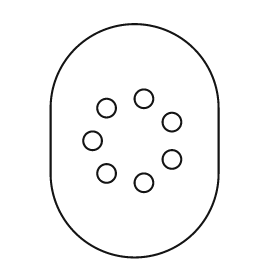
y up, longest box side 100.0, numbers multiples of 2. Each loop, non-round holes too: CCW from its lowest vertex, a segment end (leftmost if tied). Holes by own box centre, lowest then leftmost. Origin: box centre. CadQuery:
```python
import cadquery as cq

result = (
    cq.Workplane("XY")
    .moveTo(-36.0, -14.0)
    .threePointArc((0.0, -50.0), (36.0, -14.0))
    .lineTo(36.0, 14.0)
    .threePointArc((0.0, 50.0), (-36.0, 14.0))
    .close()
    .moveTo(4.0, -18.0)
    .circle(4.0)
    .moveTo(-12.0, -14.0)
    .circle(4.0)
    .moveTo(16.0, -8.0)
    .circle(4.0)
    .moveTo(-18.0, 0.0)
    .circle(4.0)
    .moveTo(16.0, 8.0)
    .circle(4.0)
    .moveTo(-12.0, 14.0)
    .circle(4.0)
    .moveTo(4.0, 18.0)
    .circle(4.0)
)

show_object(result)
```